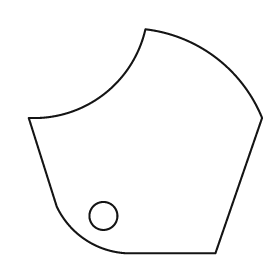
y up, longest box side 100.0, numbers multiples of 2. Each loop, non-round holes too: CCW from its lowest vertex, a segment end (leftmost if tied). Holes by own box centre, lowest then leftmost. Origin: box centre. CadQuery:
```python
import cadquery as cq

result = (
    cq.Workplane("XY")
    .moveTo(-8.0, -48.0)
    .lineTo(30.0, -48.0)
    .lineTo(50.0, 10.0)
    .threePointArc((30.0, 36.0), (0.0, 48.0))
    .threePointArc((-18.0, 20.0), (-50.0, 10.0))
    .lineTo(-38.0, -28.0)
    .threePointArc((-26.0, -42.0), (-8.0, -48.0))
    .close()
    .moveTo(-18.0, -32.0)
    .circle(6.0)
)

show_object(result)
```